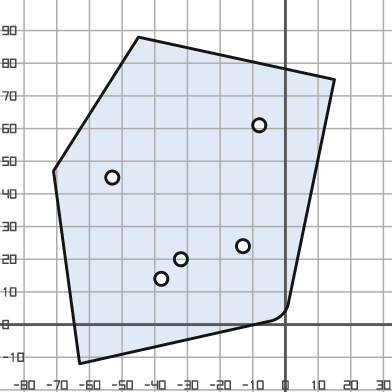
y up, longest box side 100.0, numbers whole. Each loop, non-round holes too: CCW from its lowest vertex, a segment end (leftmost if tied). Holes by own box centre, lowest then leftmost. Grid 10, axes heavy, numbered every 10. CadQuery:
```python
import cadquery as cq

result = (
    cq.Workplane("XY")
    .moveTo(-63.0, -12.0)
    .lineTo(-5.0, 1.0)
    .threePointArc((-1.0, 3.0), (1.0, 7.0))
    .lineTo(15.0, 75.0)
    .lineTo(-45.0, 88.0)
    .lineTo(-71.0, 47.0)
    .close()
    .moveTo(-38.0, 14.0)
    .circle(2.0)
    .moveTo(-32.0, 20.0)
    .circle(2.0)
    .moveTo(-13.0, 24.0)
    .circle(2.0)
    .moveTo(-53.0, 45.0)
    .circle(2.0)
    .moveTo(-8.0, 61.0)
    .circle(2.0)
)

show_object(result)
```